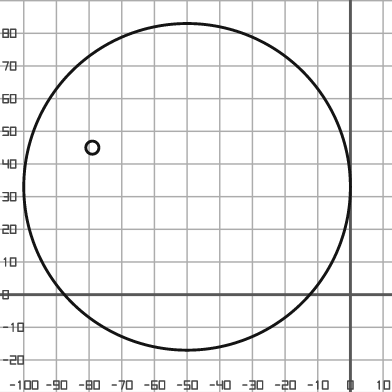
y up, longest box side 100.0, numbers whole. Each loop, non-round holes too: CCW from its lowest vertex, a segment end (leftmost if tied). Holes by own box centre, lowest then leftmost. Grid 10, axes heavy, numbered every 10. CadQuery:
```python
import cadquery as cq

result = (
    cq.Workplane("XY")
    .moveTo(-50.0, 33.0)
    .circle(50.0)
    .moveTo(-79.0, 45.0)
    .circle(2.0)
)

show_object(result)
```